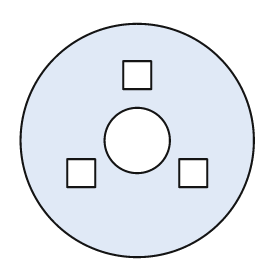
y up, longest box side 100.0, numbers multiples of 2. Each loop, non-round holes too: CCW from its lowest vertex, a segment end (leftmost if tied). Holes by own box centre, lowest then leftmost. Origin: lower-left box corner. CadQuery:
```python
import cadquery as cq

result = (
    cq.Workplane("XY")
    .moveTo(50.0, 50.0)
    .circle(50.0)
    .moveTo(20.0, 30.0)
    .lineTo(32.0, 30.0)
    .lineTo(32.0, 42.0)
    .lineTo(20.0, 42.0)
    .close()
    .moveTo(68.0, 30.0)
    .lineTo(80.0, 30.0)
    .lineTo(80.0, 42.0)
    .lineTo(68.0, 42.0)
    .close()
    .moveTo(50.0, 50.0)
    .circle(14.0)
    .moveTo(44.0, 72.0)
    .lineTo(56.0, 72.0)
    .lineTo(56.0, 84.0)
    .lineTo(44.0, 84.0)
    .close()
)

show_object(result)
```